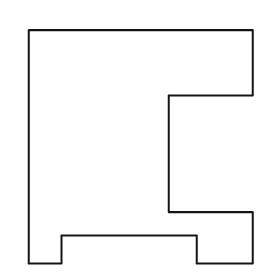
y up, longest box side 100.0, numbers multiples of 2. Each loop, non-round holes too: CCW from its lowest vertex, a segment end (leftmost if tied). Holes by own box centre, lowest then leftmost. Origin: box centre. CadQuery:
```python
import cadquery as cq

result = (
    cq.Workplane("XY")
    .moveTo(-48.0, -50.0)
    .lineTo(-34.0, -50.0)
    .lineTo(-34.0, -38.0)
    .lineTo(24.0, -38.0)
    .lineTo(24.0, -50.0)
    .lineTo(48.0, -50.0)
    .lineTo(48.0, -28.0)
    .lineTo(12.0, -28.0)
    .lineTo(12.0, 22.0)
    .lineTo(48.0, 22.0)
    .lineTo(48.0, 50.0)
    .lineTo(-48.0, 50.0)
    .close()
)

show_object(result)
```